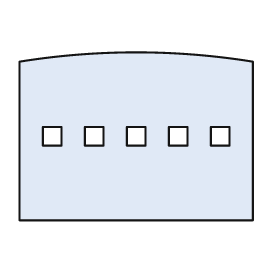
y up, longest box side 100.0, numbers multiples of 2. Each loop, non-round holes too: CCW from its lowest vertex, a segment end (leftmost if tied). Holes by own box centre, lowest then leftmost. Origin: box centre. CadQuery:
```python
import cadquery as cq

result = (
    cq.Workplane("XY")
    .moveTo(-50.0, -36.0)
    .lineTo(50.0, -36.0)
    .lineTo(50.0, 32.0)
    .threePointArc((0.0, 36.0), (-50.0, 32.0))
    .close()
    .moveTo(-40.0, -4.0)
    .lineTo(-32.0, -4.0)
    .lineTo(-32.0, 4.0)
    .lineTo(-40.0, 4.0)
    .close()
    .moveTo(-22.0, -4.0)
    .lineTo(-14.0, -4.0)
    .lineTo(-14.0, 4.0)
    .lineTo(-22.0, 4.0)
    .close()
    .moveTo(-4.0, -4.0)
    .lineTo(4.0, -4.0)
    .lineTo(4.0, 4.0)
    .lineTo(-4.0, 4.0)
    .close()
    .moveTo(14.0, -4.0)
    .lineTo(22.0, -4.0)
    .lineTo(22.0, 4.0)
    .lineTo(14.0, 4.0)
    .close()
    .moveTo(32.0, -4.0)
    .lineTo(40.0, -4.0)
    .lineTo(40.0, 4.0)
    .lineTo(32.0, 4.0)
    .close()
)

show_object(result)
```